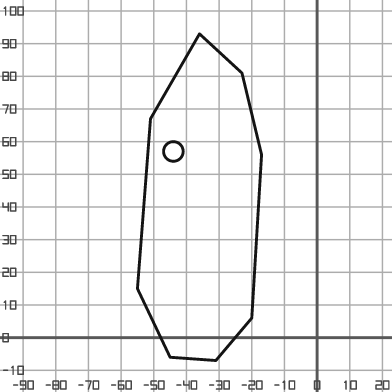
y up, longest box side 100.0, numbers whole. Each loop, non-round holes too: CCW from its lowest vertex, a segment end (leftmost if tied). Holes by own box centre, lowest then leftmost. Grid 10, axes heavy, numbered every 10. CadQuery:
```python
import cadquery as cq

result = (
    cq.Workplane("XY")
    .moveTo(-31.0, -7.0)
    .lineTo(-20.0, 6.0)
    .lineTo(-17.0, 56.0)
    .lineTo(-23.0, 81.0)
    .lineTo(-36.0, 93.0)
    .lineTo(-51.0, 67.0)
    .lineTo(-55.0, 15.0)
    .lineTo(-45.0, -6.0)
    .close()
    .moveTo(-44.0, 57.0)
    .circle(3.0)
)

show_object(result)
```